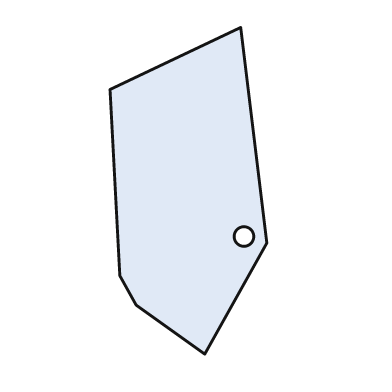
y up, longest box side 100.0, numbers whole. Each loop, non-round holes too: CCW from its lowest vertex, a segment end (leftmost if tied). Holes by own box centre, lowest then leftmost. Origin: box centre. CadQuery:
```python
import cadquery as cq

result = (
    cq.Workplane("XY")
    .moveTo(5.0, -50.0)
    .lineTo(24.0, -16.0)
    .lineTo(16.0, 50.0)
    .lineTo(-24.0, 31.0)
    .lineTo(-21.0, -26.0)
    .lineTo(-16.0, -35.0)
    .close()
    .moveTo(17.0, -14.0)
    .circle(3.0)
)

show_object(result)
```